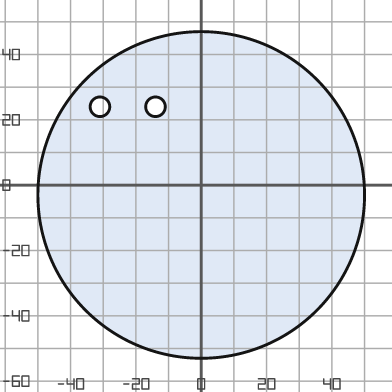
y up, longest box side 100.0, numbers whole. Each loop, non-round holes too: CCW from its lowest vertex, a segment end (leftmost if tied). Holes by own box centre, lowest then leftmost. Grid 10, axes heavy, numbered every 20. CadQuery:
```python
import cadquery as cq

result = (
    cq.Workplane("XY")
    .moveTo(0.0, -3.0)
    .circle(50.0)
    .moveTo(-31.0, 24.0)
    .circle(3.0)
    .moveTo(-14.0, 24.0)
    .circle(3.0)
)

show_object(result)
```